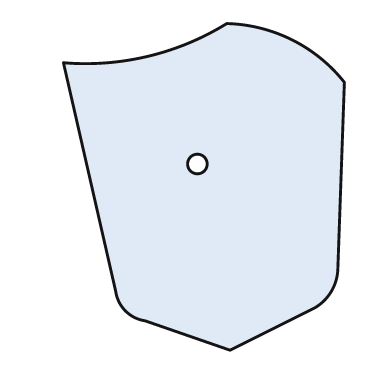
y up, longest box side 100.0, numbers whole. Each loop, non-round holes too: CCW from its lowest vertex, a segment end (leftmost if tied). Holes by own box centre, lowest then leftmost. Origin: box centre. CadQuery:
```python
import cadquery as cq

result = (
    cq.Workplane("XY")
    .moveTo(8.0, -50.0)
    .lineTo(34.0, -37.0)
    .threePointArc((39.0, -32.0), (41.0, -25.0))
    .lineTo(43.0, 32.0)
    .threePointArc((27.0, 45.0), (7.0, 50.0))
    .threePointArc((-17.0, 40.0), (-43.0, 38.0))
    .lineTo(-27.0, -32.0)
    .threePointArc((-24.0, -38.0), (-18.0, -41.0))
    .close()
    .moveTo(-2.0, 7.0)
    .circle(3.0)
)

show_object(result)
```